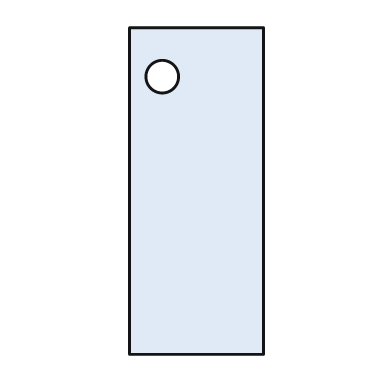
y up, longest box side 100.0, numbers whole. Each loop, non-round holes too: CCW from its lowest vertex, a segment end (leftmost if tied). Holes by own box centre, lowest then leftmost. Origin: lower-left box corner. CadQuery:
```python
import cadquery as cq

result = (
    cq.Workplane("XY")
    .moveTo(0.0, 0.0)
    .lineTo(41.0, 0.0)
    .lineTo(41.0, 100.0)
    .lineTo(0.0, 100.0)
    .close()
    .moveTo(10.0, 85.0)
    .circle(5.0)
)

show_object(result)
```